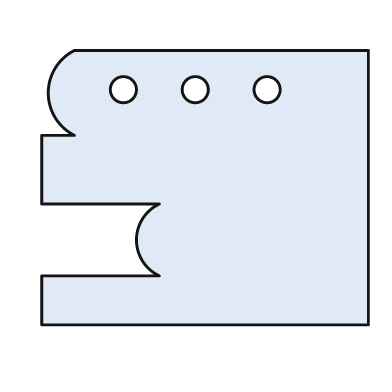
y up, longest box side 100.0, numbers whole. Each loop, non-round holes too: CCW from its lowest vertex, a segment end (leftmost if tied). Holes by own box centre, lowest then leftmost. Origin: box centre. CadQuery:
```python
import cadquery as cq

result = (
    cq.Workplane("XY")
    .moveTo(-50.0, -42.0)
    .lineTo(50.0, -42.0)
    .lineTo(50.0, 42.0)
    .lineTo(-40.0, 42.0)
    .threePointArc((-48.0, 29.0), (-40.0, 16.0))
    .lineTo(-50.0, 16.0)
    .lineTo(-50.0, -5.0)
    .lineTo(-14.0, -5.0)
    .threePointArc((-21.0, -16.0), (-14.0, -27.0))
    .lineTo(-50.0, -27.0)
    .close()
    .moveTo(-25.0, 30.0)
    .circle(4.0)
    .moveTo(-3.0, 30.0)
    .circle(4.0)
    .moveTo(19.0, 30.0)
    .circle(4.0)
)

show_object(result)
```